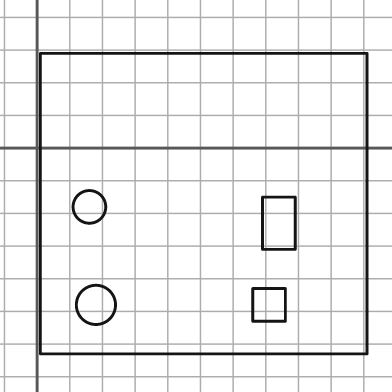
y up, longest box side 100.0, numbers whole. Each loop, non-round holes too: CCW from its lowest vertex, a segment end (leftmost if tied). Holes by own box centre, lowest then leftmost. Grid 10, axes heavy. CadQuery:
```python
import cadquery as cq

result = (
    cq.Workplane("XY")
    .moveTo(1.0, -63.0)
    .lineTo(101.0, -63.0)
    .lineTo(101.0, 29.0)
    .lineTo(1.0, 29.0)
    .close()
    .moveTo(18.0, -48.0)
    .circle(6.0)
    .moveTo(66.0, -53.0)
    .lineTo(76.0, -53.0)
    .lineTo(76.0, -43.0)
    .lineTo(66.0, -43.0)
    .close()
    .moveTo(69.0, -31.0)
    .lineTo(79.0, -31.0)
    .lineTo(79.0, -15.0)
    .lineTo(69.0, -15.0)
    .close()
    .moveTo(16.0, -18.0)
    .circle(5.0)
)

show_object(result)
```